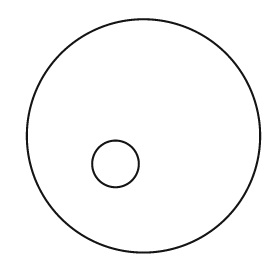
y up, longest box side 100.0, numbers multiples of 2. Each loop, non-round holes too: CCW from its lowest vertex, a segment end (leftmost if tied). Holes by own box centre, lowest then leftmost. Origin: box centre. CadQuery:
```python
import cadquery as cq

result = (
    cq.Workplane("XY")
    .moveTo(0.0, 0.0)
    .circle(50.0)
    .moveTo(-12.0, -12.0)
    .circle(10.0)
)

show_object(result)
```